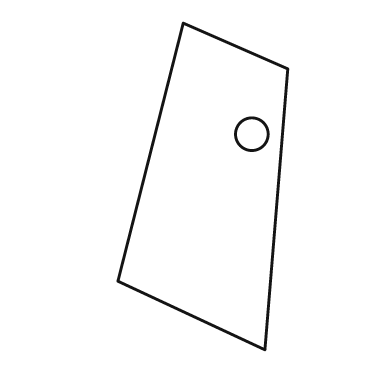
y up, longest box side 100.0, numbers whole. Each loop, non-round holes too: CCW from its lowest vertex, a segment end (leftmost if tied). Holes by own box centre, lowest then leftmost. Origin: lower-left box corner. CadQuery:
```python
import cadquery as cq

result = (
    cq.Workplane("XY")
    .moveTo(45.0, 0.0)
    .lineTo(52.0, 86.0)
    .lineTo(20.0, 100.0)
    .lineTo(0.0, 21.0)
    .close()
    .moveTo(41.0, 66.0)
    .circle(5.0)
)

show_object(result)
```